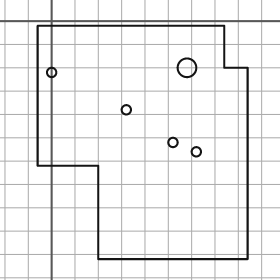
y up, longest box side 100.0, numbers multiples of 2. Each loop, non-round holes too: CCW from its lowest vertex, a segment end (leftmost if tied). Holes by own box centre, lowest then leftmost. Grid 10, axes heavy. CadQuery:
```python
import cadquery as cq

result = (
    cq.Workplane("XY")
    .moveTo(20.0, -102.0)
    .lineTo(84.0, -102.0)
    .lineTo(84.0, -20.0)
    .lineTo(74.0, -20.0)
    .lineTo(74.0, -2.0)
    .lineTo(-6.0, -2.0)
    .lineTo(-6.0, -62.0)
    .lineTo(20.0, -62.0)
    .close()
    .moveTo(62.0, -56.0)
    .circle(2.0)
    .moveTo(52.0, -52.0)
    .circle(2.0)
    .moveTo(32.0, -38.0)
    .circle(2.0)
    .moveTo(0.0, -22.0)
    .circle(2.0)
    .moveTo(58.0, -20.0)
    .circle(4.0)
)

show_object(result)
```